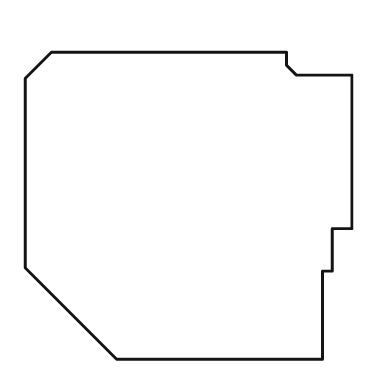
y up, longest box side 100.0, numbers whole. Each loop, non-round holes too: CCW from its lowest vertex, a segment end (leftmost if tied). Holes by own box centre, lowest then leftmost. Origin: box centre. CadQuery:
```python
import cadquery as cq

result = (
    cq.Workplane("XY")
    .moveTo(-22.0, -47.0)
    .lineTo(41.0, -47.0)
    .lineTo(41.0, -20.0)
    .lineTo(44.0, -20.0)
    .lineTo(44.0, -7.0)
    .lineTo(50.0, -7.0)
    .lineTo(50.0, 40.0)
    .lineTo(33.0, 40.0)
    .lineTo(30.0, 43.0)
    .lineTo(30.0, 47.0)
    .lineTo(-42.0, 47.0)
    .lineTo(-50.0, 39.0)
    .lineTo(-50.0, -19.0)
    .close()
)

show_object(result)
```